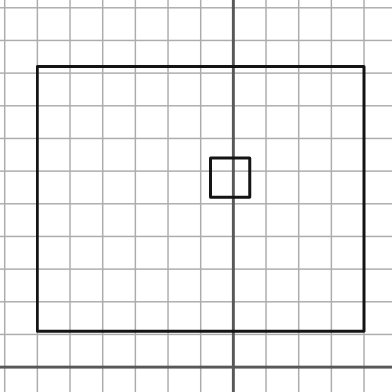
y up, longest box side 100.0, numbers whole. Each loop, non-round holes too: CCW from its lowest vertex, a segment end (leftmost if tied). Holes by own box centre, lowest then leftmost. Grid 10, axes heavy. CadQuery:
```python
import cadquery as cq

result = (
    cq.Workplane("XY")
    .moveTo(-60.0, 11.0)
    .lineTo(40.0, 11.0)
    .lineTo(40.0, 92.0)
    .lineTo(-60.0, 92.0)
    .close()
    .moveTo(-7.0, 52.0)
    .lineTo(5.0, 52.0)
    .lineTo(5.0, 64.0)
    .lineTo(-7.0, 64.0)
    .close()
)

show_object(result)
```